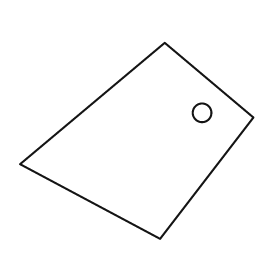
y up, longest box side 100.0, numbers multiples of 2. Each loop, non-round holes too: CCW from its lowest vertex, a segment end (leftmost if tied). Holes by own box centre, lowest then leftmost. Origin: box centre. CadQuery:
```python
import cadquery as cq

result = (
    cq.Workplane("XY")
    .moveTo(10.0, -42.0)
    .lineTo(50.0, 10.0)
    .lineTo(12.0, 42.0)
    .lineTo(-50.0, -10.0)
    .close()
    .moveTo(28.0, 12.0)
    .circle(4.0)
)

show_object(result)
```